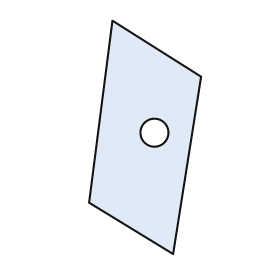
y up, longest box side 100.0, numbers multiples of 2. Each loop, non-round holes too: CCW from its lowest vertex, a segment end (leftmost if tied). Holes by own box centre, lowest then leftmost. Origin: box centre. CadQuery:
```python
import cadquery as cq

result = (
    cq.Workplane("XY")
    .moveTo(12.0, -50.0)
    .lineTo(24.0, 26.0)
    .lineTo(-14.0, 50.0)
    .lineTo(-24.0, -28.0)
    .close()
    .moveTo(4.0, 2.0)
    .circle(6.0)
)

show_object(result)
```